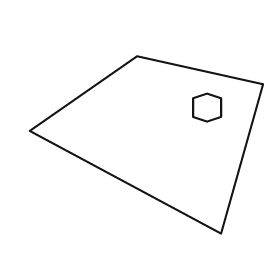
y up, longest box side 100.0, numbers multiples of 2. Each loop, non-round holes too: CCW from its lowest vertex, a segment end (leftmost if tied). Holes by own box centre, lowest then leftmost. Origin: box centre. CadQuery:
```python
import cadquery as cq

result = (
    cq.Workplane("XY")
    .moveTo(32.0, -38.0)
    .lineTo(50.0, 26.0)
    .lineTo(-4.0, 38.0)
    .lineTo(-50.0, 6.0)
    .close()
    .moveTo(26.0, 10.0)
    .lineTo(32.0, 12.0)
    .lineTo(32.0, 20.0)
    .lineTo(26.0, 22.0)
    .lineTo(20.0, 20.0)
    .lineTo(20.0, 12.0)
    .close()
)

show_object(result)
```